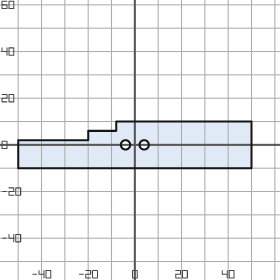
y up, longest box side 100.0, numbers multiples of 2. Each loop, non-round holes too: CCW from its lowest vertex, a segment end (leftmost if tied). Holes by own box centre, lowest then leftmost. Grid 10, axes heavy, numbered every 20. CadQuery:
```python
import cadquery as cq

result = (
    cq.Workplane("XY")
    .moveTo(-50.0, -10.0)
    .lineTo(50.0, -10.0)
    .lineTo(50.0, 10.0)
    .lineTo(-8.0, 10.0)
    .lineTo(-8.0, 6.0)
    .lineTo(-20.0, 6.0)
    .lineTo(-20.0, 2.0)
    .lineTo(-50.0, 2.0)
    .close()
    .moveTo(-4.0, 0.0)
    .circle(2.0)
    .moveTo(4.0, 0.0)
    .circle(2.0)
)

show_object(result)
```